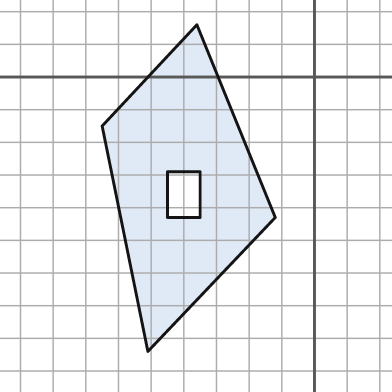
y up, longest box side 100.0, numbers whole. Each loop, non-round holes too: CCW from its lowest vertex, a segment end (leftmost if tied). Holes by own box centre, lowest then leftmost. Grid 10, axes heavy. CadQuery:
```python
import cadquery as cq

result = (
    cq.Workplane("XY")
    .moveTo(-51.0, -84.0)
    .lineTo(-12.0, -43.0)
    .lineTo(-36.0, 16.0)
    .lineTo(-65.0, -15.0)
    .close()
    .moveTo(-45.0, -43.0)
    .lineTo(-35.0, -43.0)
    .lineTo(-35.0, -29.0)
    .lineTo(-45.0, -29.0)
    .close()
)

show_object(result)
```